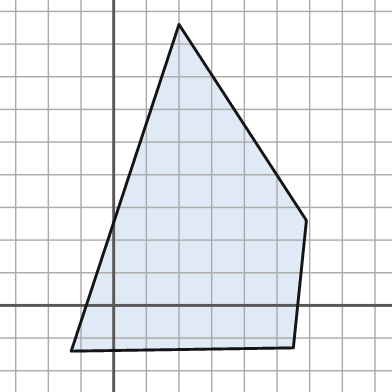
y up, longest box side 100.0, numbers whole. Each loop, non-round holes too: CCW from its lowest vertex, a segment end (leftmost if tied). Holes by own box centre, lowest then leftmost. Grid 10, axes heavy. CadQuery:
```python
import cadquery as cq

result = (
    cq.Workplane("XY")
    .moveTo(-13.0, -14.0)
    .lineTo(55.0, -13.0)
    .lineTo(59.0, 26.0)
    .lineTo(20.0, 86.0)
    .close()
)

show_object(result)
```